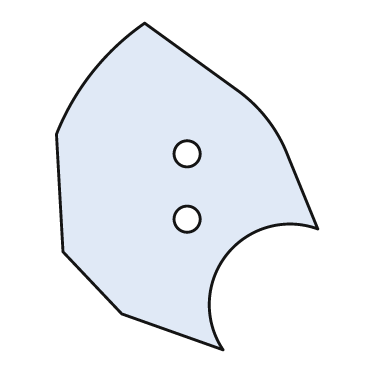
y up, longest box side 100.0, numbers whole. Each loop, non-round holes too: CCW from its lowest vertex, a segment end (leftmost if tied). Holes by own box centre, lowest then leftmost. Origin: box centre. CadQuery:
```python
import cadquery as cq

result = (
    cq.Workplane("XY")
    .moveTo(11.0, -50.0)
    .threePointArc((12.0, -21.0), (40.0, -13.0))
    .lineTo(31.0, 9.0)
    .threePointArc((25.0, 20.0), (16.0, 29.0))
    .lineTo(-13.0, 50.0)
    .threePointArc((-29.0, 35.0), (-40.0, 16.0))
    .lineTo(-38.0, -20.0)
    .lineTo(-20.0, -39.0)
    .close()
    .moveTo(0.0, -10.0)
    .circle(4.0)
    .moveTo(0.0, 10.0)
    .circle(4.0)
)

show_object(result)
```